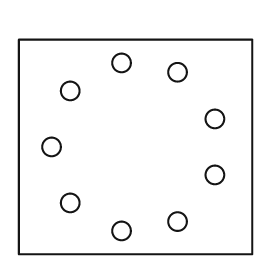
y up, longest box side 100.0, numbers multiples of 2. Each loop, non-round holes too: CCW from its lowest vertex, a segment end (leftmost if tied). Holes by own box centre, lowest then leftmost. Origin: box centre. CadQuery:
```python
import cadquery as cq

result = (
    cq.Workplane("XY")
    .moveTo(-50.0, -46.0)
    .lineTo(50.0, -46.0)
    .lineTo(50.0, 46.0)
    .lineTo(-50.0, 46.0)
    .close()
    .moveTo(-6.0, -36.0)
    .circle(4.0)
    .moveTo(18.0, -32.0)
    .circle(4.0)
    .moveTo(-28.0, -24.0)
    .circle(4.0)
    .moveTo(34.0, -12.0)
    .circle(4.0)
    .moveTo(-36.0, 0.0)
    .circle(4.0)
    .moveTo(34.0, 12.0)
    .circle(4.0)
    .moveTo(-28.0, 24.0)
    .circle(4.0)
    .moveTo(18.0, 32.0)
    .circle(4.0)
    .moveTo(-6.0, 36.0)
    .circle(4.0)
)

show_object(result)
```